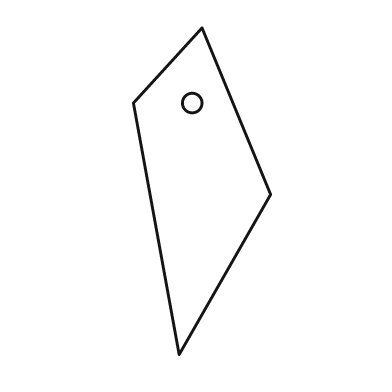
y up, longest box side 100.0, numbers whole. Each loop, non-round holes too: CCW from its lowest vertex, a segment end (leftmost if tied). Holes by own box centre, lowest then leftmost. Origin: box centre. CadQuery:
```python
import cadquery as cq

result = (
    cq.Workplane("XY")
    .moveTo(-7.0, -50.0)
    .lineTo(21.0, -1.0)
    .lineTo(0.0, 50.0)
    .lineTo(-21.0, 27.0)
    .close()
    .moveTo(-3.0, 27.0)
    .circle(3.0)
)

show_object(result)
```